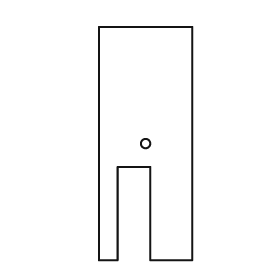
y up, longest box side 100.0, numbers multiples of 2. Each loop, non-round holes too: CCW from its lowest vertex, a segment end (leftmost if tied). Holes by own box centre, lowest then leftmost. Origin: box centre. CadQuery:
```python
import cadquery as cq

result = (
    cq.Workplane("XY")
    .moveTo(-20.0, -50.0)
    .lineTo(-12.0, -50.0)
    .lineTo(-12.0, -10.0)
    .lineTo(2.0, -10.0)
    .lineTo(2.0, -50.0)
    .lineTo(20.0, -50.0)
    .lineTo(20.0, 50.0)
    .lineTo(-20.0, 50.0)
    .close()
    .moveTo(0.0, 0.0)
    .circle(2.0)
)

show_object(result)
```